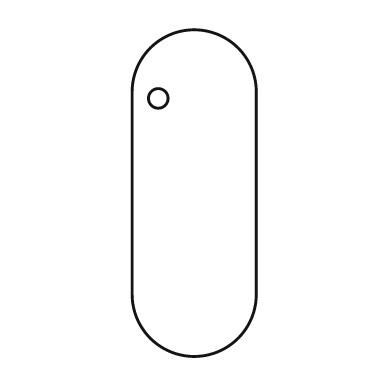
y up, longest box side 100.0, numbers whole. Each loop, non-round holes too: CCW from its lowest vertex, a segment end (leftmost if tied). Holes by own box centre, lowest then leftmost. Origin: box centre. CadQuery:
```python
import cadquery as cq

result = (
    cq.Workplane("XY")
    .moveTo(-19.0, -31.0)
    .threePointArc((0.0, -50.0), (19.0, -31.0))
    .lineTo(19.0, 31.0)
    .threePointArc((0.0, 50.0), (-19.0, 31.0))
    .close()
    .moveTo(-11.0, 29.0)
    .circle(3.0)
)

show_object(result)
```